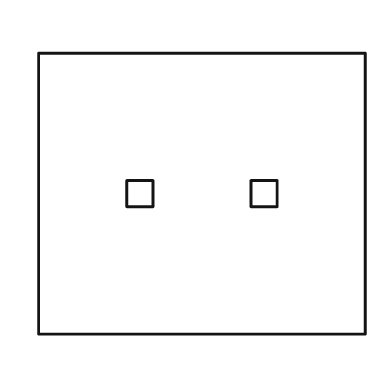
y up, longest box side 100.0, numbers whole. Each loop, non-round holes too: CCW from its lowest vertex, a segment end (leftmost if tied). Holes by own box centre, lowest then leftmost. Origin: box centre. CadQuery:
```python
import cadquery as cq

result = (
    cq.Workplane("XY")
    .moveTo(-50.0, -43.0)
    .lineTo(50.0, -43.0)
    .lineTo(50.0, 43.0)
    .lineTo(-50.0, 43.0)
    .close()
    .moveTo(-23.0, -4.0)
    .lineTo(-15.0, -4.0)
    .lineTo(-15.0, 4.0)
    .lineTo(-23.0, 4.0)
    .close()
    .moveTo(15.0, -4.0)
    .lineTo(23.0, -4.0)
    .lineTo(23.0, 4.0)
    .lineTo(15.0, 4.0)
    .close()
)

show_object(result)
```